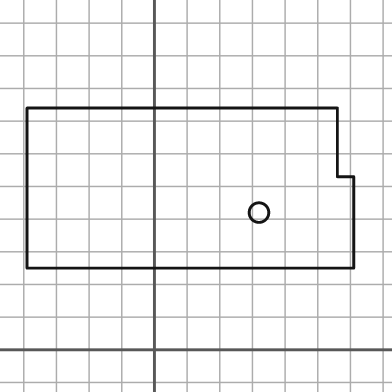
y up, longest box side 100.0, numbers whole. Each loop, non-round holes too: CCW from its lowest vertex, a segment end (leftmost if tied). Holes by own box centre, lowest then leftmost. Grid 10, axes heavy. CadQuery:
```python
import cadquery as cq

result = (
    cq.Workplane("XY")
    .moveTo(-39.0, 25.0)
    .lineTo(61.0, 25.0)
    .lineTo(61.0, 53.0)
    .lineTo(56.0, 53.0)
    .lineTo(56.0, 74.0)
    .lineTo(-39.0, 74.0)
    .close()
    .moveTo(32.0, 42.0)
    .circle(3.0)
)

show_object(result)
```